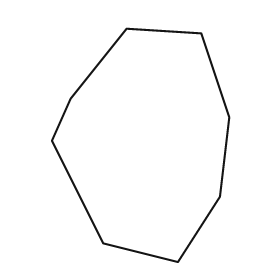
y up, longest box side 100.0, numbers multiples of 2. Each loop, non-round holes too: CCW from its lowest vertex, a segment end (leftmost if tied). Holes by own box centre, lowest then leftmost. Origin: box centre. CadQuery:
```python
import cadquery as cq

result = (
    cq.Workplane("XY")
    .moveTo(16.0, -50.0)
    .lineTo(34.0, -22.0)
    .lineTo(38.0, 12.0)
    .lineTo(26.0, 48.0)
    .lineTo(-6.0, 50.0)
    .lineTo(-30.0, 20.0)
    .lineTo(-38.0, 2.0)
    .lineTo(-16.0, -42.0)
    .close()
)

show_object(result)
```